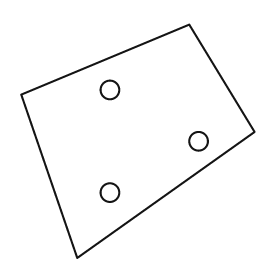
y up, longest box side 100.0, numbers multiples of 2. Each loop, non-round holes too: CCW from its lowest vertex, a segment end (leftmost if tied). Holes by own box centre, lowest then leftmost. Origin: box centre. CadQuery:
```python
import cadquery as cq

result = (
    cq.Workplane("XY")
    .moveTo(-26.0, -50.0)
    .lineTo(50.0, 4.0)
    .lineTo(22.0, 50.0)
    .lineTo(-50.0, 20.0)
    .close()
    .moveTo(-12.0, -22.0)
    .circle(4.0)
    .moveTo(26.0, 0.0)
    .circle(4.0)
    .moveTo(-12.0, 22.0)
    .circle(4.0)
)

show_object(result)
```